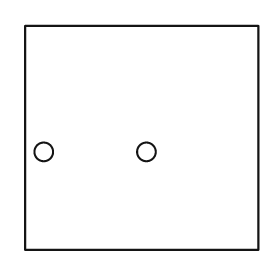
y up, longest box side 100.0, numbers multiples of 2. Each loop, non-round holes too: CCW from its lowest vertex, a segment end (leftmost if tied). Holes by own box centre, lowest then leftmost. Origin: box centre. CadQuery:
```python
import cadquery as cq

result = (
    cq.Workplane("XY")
    .moveTo(-50.0, -48.0)
    .lineTo(50.0, -48.0)
    .lineTo(50.0, 48.0)
    .lineTo(-50.0, 48.0)
    .close()
    .moveTo(-42.0, -6.0)
    .circle(4.0)
    .moveTo(2.0, -6.0)
    .circle(4.0)
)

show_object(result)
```